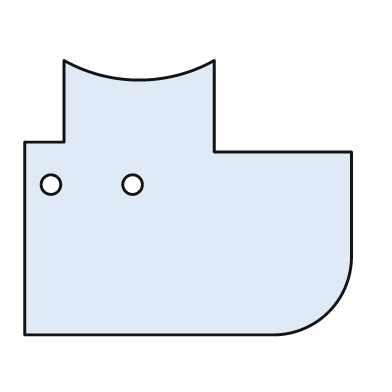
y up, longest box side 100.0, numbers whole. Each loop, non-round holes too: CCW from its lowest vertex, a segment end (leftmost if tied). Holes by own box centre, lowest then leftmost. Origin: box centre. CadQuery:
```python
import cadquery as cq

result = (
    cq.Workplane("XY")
    .moveTo(-50.0, -42.0)
    .lineTo(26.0, -42.0)
    .threePointArc((43.0, -35.0), (50.0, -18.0))
    .lineTo(50.0, 14.0)
    .lineTo(8.0, 14.0)
    .lineTo(8.0, 42.0)
    .threePointArc((-15.0, 36.0), (-38.0, 42.0))
    .lineTo(-38.0, 17.0)
    .lineTo(-50.0, 17.0)
    .close()
    .moveTo(-42.0, 4.0)
    .circle(3.0)
    .moveTo(-17.0, 4.0)
    .circle(3.0)
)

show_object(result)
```